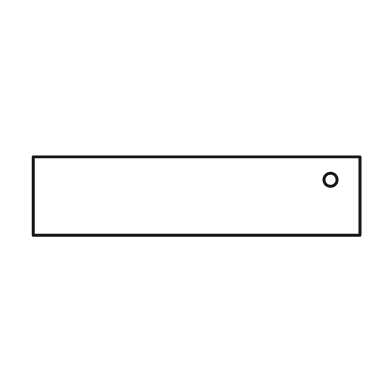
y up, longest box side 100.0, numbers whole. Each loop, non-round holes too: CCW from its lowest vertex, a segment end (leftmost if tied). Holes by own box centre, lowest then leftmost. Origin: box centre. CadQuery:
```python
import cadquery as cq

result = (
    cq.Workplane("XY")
    .moveTo(-50.0, -12.0)
    .lineTo(50.0, -12.0)
    .lineTo(50.0, 12.0)
    .lineTo(-50.0, 12.0)
    .close()
    .moveTo(41.0, 5.0)
    .circle(2.0)
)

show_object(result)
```